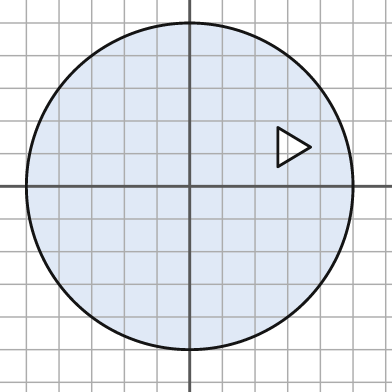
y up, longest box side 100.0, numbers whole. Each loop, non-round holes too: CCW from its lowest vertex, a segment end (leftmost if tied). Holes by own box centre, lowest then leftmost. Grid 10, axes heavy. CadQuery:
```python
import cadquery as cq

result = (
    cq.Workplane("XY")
    .moveTo(0.0, 0.0)
    .circle(50.0)
    .moveTo(27.0, 6.0)
    .lineTo(37.0, 12.0)
    .lineTo(27.0, 18.0)
    .close()
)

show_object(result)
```